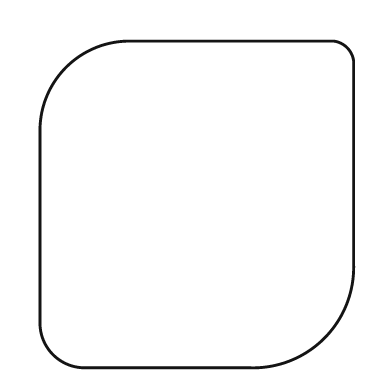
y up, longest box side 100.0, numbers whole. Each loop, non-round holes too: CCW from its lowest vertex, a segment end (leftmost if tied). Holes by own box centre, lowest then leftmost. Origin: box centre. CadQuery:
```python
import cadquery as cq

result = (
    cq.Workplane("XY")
    .moveTo(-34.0, -50.0)
    .lineTo(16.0, -50.0)
    .threePointArc((39.0, -41.0), (48.0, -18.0))
    .lineTo(48.0, 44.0)
    .threePointArc((46.0, 48.0), (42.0, 50.0))
    .lineTo(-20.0, 50.0)
    .threePointArc((-40.0, 42.0), (-48.0, 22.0))
    .lineTo(-48.0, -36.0)
    .threePointArc((-44.0, -46.0), (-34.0, -50.0))
    .close()
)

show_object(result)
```